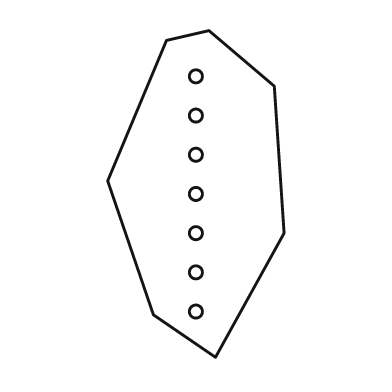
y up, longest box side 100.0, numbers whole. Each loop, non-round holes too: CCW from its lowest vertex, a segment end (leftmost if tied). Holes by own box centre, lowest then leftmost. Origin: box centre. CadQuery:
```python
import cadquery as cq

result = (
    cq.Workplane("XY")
    .moveTo(6.0, -50.0)
    .lineTo(27.0, -12.0)
    .lineTo(24.0, 33.0)
    .lineTo(4.0, 50.0)
    .lineTo(-9.0, 47.0)
    .lineTo(-27.0, 4.0)
    .lineTo(-13.0, -37.0)
    .close()
    .moveTo(0.0, -36.0)
    .circle(2.0)
    .moveTo(0.0, -24.0)
    .circle(2.0)
    .moveTo(0.0, -12.0)
    .circle(2.0)
    .moveTo(0.0, 0.0)
    .circle(2.0)
    .moveTo(0.0, 12.0)
    .circle(2.0)
    .moveTo(0.0, 24.0)
    .circle(2.0)
    .moveTo(0.0, 36.0)
    .circle(2.0)
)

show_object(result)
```